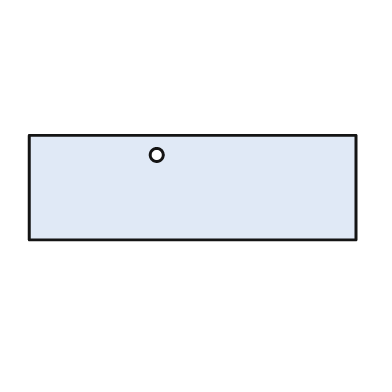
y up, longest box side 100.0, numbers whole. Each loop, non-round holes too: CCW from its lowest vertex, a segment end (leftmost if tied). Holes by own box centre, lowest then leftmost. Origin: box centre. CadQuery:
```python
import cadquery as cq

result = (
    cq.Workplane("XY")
    .moveTo(-50.0, -16.0)
    .lineTo(50.0, -16.0)
    .lineTo(50.0, 16.0)
    .lineTo(-50.0, 16.0)
    .close()
    .moveTo(-11.0, 10.0)
    .circle(2.0)
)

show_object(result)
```